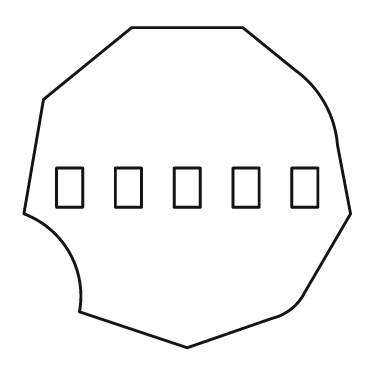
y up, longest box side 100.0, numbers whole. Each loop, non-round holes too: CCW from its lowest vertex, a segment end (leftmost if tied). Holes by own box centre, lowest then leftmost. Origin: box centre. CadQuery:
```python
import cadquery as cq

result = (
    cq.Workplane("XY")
    .moveTo(0.0, -49.0)
    .lineTo(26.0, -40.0)
    .threePointArc((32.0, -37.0), (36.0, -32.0))
    .lineTo(50.0, -8.0)
    .lineTo(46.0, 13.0)
    .threePointArc((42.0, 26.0), (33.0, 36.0))
    .lineTo(17.0, 49.0)
    .lineTo(-17.0, 49.0)
    .lineTo(-44.0, 27.0)
    .lineTo(-50.0, -8.0)
    .threePointArc((-36.0, -20.0), (-33.0, -38.0))
    .close()
    .moveTo(-40.0, -6.0)
    .lineTo(-32.0, -6.0)
    .lineTo(-32.0, 6.0)
    .lineTo(-40.0, 6.0)
    .close()
    .moveTo(-22.0, -6.0)
    .lineTo(-14.0, -6.0)
    .lineTo(-14.0, 6.0)
    .lineTo(-22.0, 6.0)
    .close()
    .moveTo(-4.0, -6.0)
    .lineTo(4.0, -6.0)
    .lineTo(4.0, 6.0)
    .lineTo(-4.0, 6.0)
    .close()
    .moveTo(14.0, -6.0)
    .lineTo(22.0, -6.0)
    .lineTo(22.0, 6.0)
    .lineTo(14.0, 6.0)
    .close()
    .moveTo(32.0, -6.0)
    .lineTo(40.0, -6.0)
    .lineTo(40.0, 6.0)
    .lineTo(32.0, 6.0)
    .close()
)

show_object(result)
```